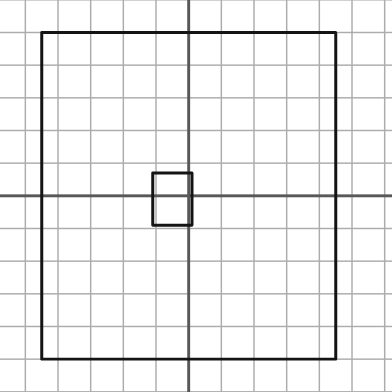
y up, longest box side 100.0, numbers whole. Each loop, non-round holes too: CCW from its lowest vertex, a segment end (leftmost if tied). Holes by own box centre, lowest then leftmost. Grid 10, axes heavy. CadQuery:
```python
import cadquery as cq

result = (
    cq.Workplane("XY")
    .moveTo(-45.0, -50.0)
    .lineTo(45.0, -50.0)
    .lineTo(45.0, 50.0)
    .lineTo(-45.0, 50.0)
    .close()
    .moveTo(-11.0, -9.0)
    .lineTo(1.0, -9.0)
    .lineTo(1.0, 7.0)
    .lineTo(-11.0, 7.0)
    .close()
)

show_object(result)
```